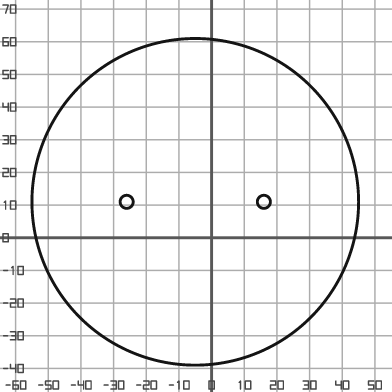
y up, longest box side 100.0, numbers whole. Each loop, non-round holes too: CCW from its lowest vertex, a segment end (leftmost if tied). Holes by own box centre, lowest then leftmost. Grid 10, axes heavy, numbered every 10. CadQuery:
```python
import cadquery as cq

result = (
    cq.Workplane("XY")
    .moveTo(-5.0, 11.0)
    .circle(50.0)
    .moveTo(-26.0, 11.0)
    .circle(2.0)
    .moveTo(16.0, 11.0)
    .circle(2.0)
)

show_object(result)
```